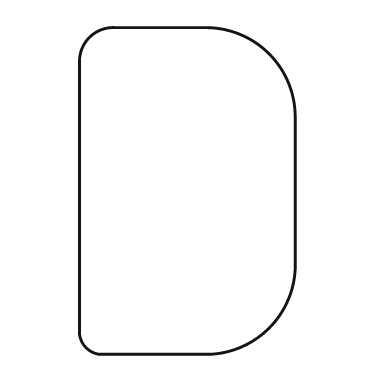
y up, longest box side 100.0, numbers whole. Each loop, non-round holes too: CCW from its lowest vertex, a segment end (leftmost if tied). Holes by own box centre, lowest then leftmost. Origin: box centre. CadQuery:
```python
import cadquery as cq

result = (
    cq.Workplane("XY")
    .moveTo(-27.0, -50.0)
    .lineTo(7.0, -50.0)
    .threePointArc((25.0, -42.0), (33.0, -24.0))
    .lineTo(33.0, 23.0)
    .threePointArc((25.0, 42.0), (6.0, 50.0))
    .lineTo(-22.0, 50.0)
    .threePointArc((-30.0, 47.0), (-33.0, 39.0))
    .lineTo(-33.0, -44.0)
    .threePointArc((-31.0, -48.0), (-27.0, -50.0))
    .close()
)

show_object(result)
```